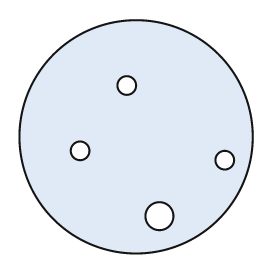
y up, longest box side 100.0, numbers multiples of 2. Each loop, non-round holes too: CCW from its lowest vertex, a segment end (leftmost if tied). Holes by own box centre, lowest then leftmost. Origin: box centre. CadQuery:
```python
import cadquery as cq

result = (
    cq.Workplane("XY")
    .moveTo(0.0, 0.0)
    .circle(50.0)
    .moveTo(10.0, -34.0)
    .circle(6.0)
    .moveTo(38.0, -10.0)
    .circle(4.0)
    .moveTo(-24.0, -6.0)
    .circle(4.0)
    .moveTo(-4.0, 22.0)
    .circle(4.0)
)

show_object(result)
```